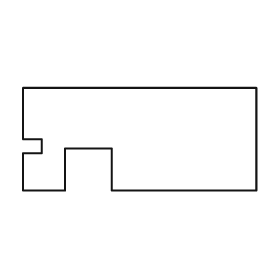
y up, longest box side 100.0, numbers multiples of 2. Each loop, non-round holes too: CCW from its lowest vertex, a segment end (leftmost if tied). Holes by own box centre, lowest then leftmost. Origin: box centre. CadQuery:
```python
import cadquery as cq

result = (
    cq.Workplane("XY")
    .moveTo(-50.0, -22.0)
    .lineTo(-32.0, -22.0)
    .lineTo(-32.0, -4.0)
    .lineTo(-12.0, -4.0)
    .lineTo(-12.0, -22.0)
    .lineTo(50.0, -22.0)
    .lineTo(50.0, 22.0)
    .lineTo(-50.0, 22.0)
    .lineTo(-50.0, 0.0)
    .lineTo(-42.0, 0.0)
    .lineTo(-42.0, -6.0)
    .lineTo(-50.0, -6.0)
    .close()
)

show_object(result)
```